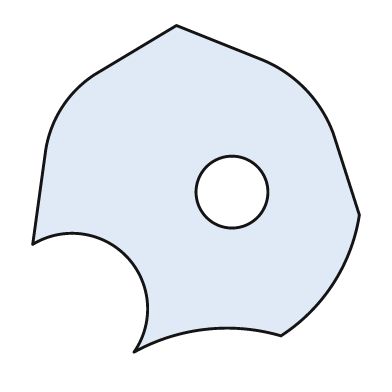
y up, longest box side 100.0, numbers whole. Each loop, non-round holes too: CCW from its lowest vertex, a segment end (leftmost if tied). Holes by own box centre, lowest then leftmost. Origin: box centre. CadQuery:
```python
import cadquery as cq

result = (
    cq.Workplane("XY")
    .moveTo(-19.0, -50.0)
    .threePointArc((3.0, -43.0), (26.0, -45.0))
    .threePointArc((42.0, -29.0), (50.0, -8.0))
    .lineTo(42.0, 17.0)
    .threePointArc((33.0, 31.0), (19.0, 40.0))
    .lineTo(-6.0, 50.0)
    .lineTo(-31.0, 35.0)
    .threePointArc((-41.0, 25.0), (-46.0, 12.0))
    .lineTo(-50.0, -17.0)
    .threePointArc((-21.0, -21.0), (-19.0, -50.0))
    .close()
    .moveTo(11.0, -1.0)
    .circle(11.0)
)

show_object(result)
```